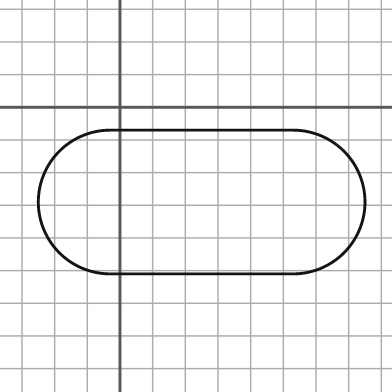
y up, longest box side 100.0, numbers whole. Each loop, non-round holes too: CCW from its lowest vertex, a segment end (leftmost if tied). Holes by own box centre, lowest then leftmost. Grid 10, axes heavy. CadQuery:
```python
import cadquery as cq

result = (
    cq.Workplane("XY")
    .moveTo(-3.0, -51.0)
    .lineTo(53.0, -51.0)
    .threePointArc((75.0, -29.0), (53.0, -7.0))
    .lineTo(-3.0, -7.0)
    .threePointArc((-25.0, -29.0), (-3.0, -51.0))
    .close()
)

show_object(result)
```